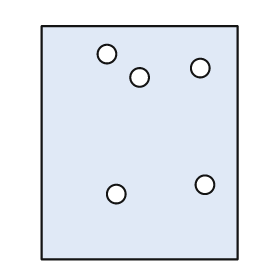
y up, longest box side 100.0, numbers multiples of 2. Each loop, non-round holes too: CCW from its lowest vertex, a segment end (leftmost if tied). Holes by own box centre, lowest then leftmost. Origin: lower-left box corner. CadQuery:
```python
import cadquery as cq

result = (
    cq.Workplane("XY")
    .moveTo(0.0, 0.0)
    .lineTo(84.0, 0.0)
    .lineTo(84.0, 100.0)
    .lineTo(0.0, 100.0)
    .close()
    .moveTo(32.0, 28.0)
    .circle(4.0)
    .moveTo(70.0, 32.0)
    .circle(4.0)
    .moveTo(42.0, 78.0)
    .circle(4.0)
    .moveTo(68.0, 82.0)
    .circle(4.0)
    .moveTo(28.0, 88.0)
    .circle(4.0)
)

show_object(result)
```